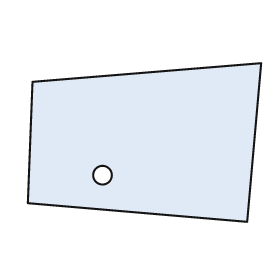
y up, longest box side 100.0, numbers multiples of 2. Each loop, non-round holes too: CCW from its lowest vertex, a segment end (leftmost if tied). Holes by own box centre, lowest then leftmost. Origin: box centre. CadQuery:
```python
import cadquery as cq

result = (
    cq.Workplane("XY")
    .moveTo(44.0, -34.0)
    .lineTo(50.0, 34.0)
    .lineTo(-48.0, 26.0)
    .lineTo(-50.0, -26.0)
    .close()
    .moveTo(-18.0, -14.0)
    .circle(4.0)
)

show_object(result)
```